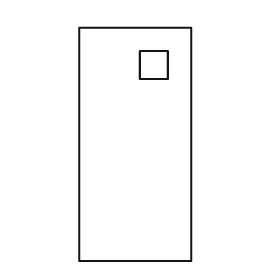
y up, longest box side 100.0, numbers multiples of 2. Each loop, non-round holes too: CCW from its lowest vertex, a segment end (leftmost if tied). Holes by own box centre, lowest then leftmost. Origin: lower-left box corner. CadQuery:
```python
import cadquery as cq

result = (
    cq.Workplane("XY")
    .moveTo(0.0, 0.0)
    .lineTo(48.0, 0.0)
    .lineTo(48.0, 100.0)
    .lineTo(0.0, 100.0)
    .close()
    .moveTo(26.0, 78.0)
    .lineTo(38.0, 78.0)
    .lineTo(38.0, 90.0)
    .lineTo(26.0, 90.0)
    .close()
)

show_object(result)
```